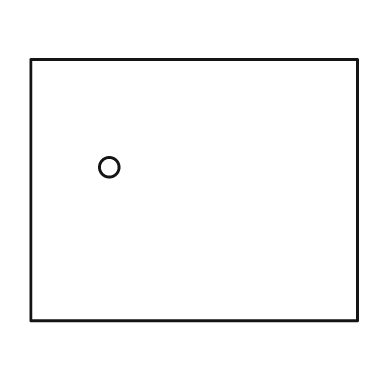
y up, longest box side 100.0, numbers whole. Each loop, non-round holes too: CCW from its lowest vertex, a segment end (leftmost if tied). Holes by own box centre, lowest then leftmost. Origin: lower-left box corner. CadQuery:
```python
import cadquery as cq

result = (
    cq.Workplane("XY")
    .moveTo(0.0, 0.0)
    .lineTo(100.0, 0.0)
    .lineTo(100.0, 80.0)
    .lineTo(0.0, 80.0)
    .close()
    .moveTo(24.0, 47.0)
    .circle(3.0)
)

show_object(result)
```